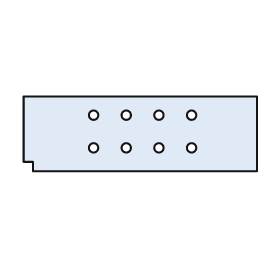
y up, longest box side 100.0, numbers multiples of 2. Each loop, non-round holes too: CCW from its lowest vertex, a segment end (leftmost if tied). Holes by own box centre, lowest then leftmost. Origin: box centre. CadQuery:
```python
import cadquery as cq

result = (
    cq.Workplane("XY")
    .moveTo(-46.0, -16.0)
    .lineTo(50.0, -16.0)
    .lineTo(50.0, 16.0)
    .lineTo(-50.0, 16.0)
    .lineTo(-50.0, -12.0)
    .lineTo(-46.0, -12.0)
    .close()
    .moveTo(-20.0, -6.0)
    .circle(2.0)
    .moveTo(-6.0, -6.0)
    .circle(2.0)
    .moveTo(8.0, -6.0)
    .circle(2.0)
    .moveTo(22.0, -6.0)
    .circle(2.0)
    .moveTo(-20.0, 8.0)
    .circle(2.0)
    .moveTo(-6.0, 8.0)
    .circle(2.0)
    .moveTo(8.0, 8.0)
    .circle(2.0)
    .moveTo(22.0, 8.0)
    .circle(2.0)
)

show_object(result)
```